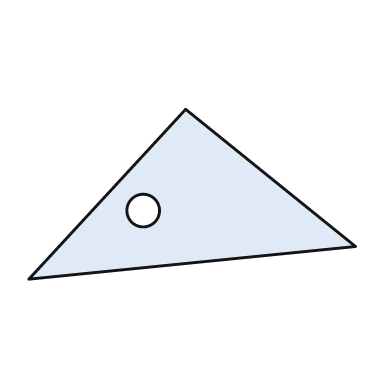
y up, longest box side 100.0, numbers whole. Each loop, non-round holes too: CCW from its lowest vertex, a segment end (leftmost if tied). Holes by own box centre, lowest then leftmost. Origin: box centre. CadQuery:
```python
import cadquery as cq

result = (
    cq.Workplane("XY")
    .moveTo(-50.0, -26.0)
    .lineTo(50.0, -16.0)
    .lineTo(-2.0, 26.0)
    .close()
    .moveTo(-15.0, -5.0)
    .circle(5.0)
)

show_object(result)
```